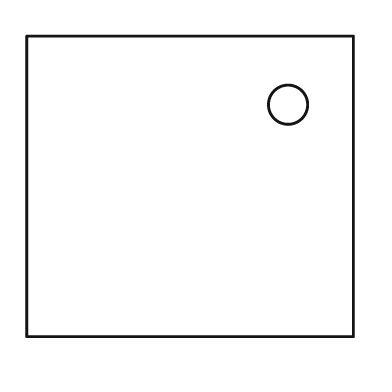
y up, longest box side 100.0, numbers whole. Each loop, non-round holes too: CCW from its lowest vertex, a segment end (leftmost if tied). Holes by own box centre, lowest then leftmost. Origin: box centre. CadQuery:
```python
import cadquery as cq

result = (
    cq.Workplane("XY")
    .moveTo(-50.0, -46.0)
    .lineTo(50.0, -46.0)
    .lineTo(50.0, 46.0)
    .lineTo(-50.0, 46.0)
    .close()
    .moveTo(30.0, 25.0)
    .circle(6.0)
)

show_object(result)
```